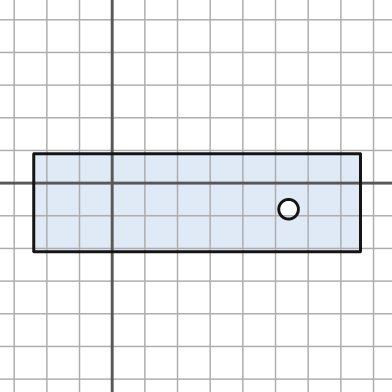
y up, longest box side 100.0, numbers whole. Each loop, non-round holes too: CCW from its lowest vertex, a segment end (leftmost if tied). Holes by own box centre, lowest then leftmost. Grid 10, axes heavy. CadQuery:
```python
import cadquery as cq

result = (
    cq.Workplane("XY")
    .moveTo(-24.0, -21.0)
    .lineTo(76.0, -21.0)
    .lineTo(76.0, 9.0)
    .lineTo(-24.0, 9.0)
    .close()
    .moveTo(54.0, -8.0)
    .circle(3.0)
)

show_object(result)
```